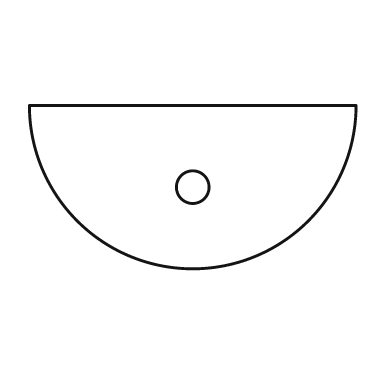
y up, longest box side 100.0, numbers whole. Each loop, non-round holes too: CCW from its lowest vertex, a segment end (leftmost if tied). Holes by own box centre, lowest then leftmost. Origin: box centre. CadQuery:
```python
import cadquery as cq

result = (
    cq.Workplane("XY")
    .moveTo(-50.0, 25.0)
    .threePointArc((0.0, -25.0), (50.0, 25.0))
    .close()
    .moveTo(0.0, 0.0)
    .circle(5.0)
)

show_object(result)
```